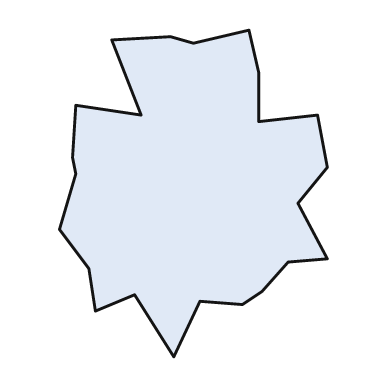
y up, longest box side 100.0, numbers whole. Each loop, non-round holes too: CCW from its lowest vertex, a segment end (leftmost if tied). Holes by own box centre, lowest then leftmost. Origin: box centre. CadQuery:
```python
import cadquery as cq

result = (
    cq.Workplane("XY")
    .moveTo(-6.0, -50.0)
    .lineTo(2.0, -33.0)
    .lineTo(15.0, -34.0)
    .lineTo(21.0, -30.0)
    .lineTo(29.0, -21.0)
    .lineTo(41.0, -20.0)
    .lineTo(32.0, -3.0)
    .lineTo(41.0, 8.0)
    .lineTo(38.0, 24.0)
    .lineTo(20.0, 22.0)
    .lineTo(20.0, 37.0)
    .lineTo(17.0, 50.0)
    .lineTo(0.0, 46.0)
    .lineTo(-7.0, 48.0)
    .lineTo(-25.0, 47.0)
    .lineTo(-16.0, 24.0)
    .lineTo(-36.0, 27.0)
    .lineTo(-37.0, 11.0)
    .lineTo(-36.0, 6.0)
    .lineTo(-41.0, -11.0)
    .lineTo(-32.0, -23.0)
    .lineTo(-30.0, -36.0)
    .lineTo(-18.0, -31.0)
    .close()
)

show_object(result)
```